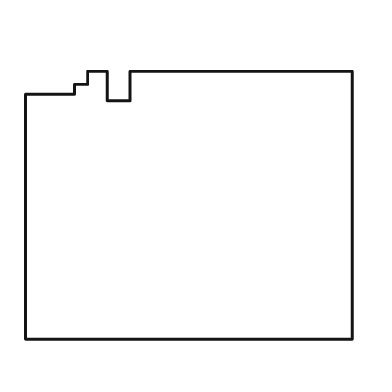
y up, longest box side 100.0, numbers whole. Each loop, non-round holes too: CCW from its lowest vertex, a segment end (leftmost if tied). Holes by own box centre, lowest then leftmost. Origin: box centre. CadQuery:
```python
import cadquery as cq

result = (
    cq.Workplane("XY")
    .moveTo(-50.0, -41.0)
    .lineTo(50.0, -41.0)
    .lineTo(50.0, 41.0)
    .lineTo(-18.0, 41.0)
    .lineTo(-18.0, 32.0)
    .lineTo(-25.0, 32.0)
    .lineTo(-25.0, 41.0)
    .lineTo(-31.0, 41.0)
    .lineTo(-31.0, 37.0)
    .lineTo(-35.0, 37.0)
    .lineTo(-35.0, 34.0)
    .lineTo(-50.0, 34.0)
    .close()
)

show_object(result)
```